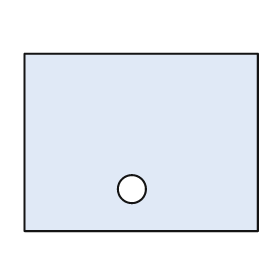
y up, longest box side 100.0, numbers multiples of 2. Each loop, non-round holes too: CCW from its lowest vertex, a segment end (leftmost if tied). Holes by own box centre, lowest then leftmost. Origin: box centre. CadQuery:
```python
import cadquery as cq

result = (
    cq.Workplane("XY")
    .moveTo(-50.0, -38.0)
    .lineTo(50.0, -38.0)
    .lineTo(50.0, 38.0)
    .lineTo(-50.0, 38.0)
    .close()
    .moveTo(-4.0, -20.0)
    .circle(6.0)
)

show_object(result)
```